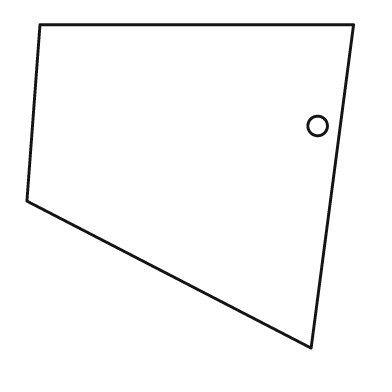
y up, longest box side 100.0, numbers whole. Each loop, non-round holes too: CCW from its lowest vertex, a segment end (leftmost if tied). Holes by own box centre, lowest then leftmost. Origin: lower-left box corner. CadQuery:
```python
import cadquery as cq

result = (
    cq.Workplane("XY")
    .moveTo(87.0, 0.0)
    .lineTo(100.0, 99.0)
    .lineTo(4.0, 99.0)
    .lineTo(0.0, 45.0)
    .close()
    .moveTo(89.0, 68.0)
    .circle(3.0)
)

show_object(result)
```